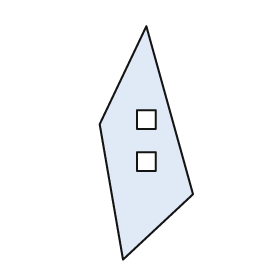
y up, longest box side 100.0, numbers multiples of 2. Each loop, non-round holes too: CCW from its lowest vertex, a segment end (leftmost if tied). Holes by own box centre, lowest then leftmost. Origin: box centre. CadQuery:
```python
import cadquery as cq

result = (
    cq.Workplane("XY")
    .moveTo(-10.0, -50.0)
    .lineTo(20.0, -22.0)
    .lineTo(0.0, 50.0)
    .lineTo(-20.0, 8.0)
    .close()
    .moveTo(-4.0, -12.0)
    .lineTo(4.0, -12.0)
    .lineTo(4.0, -4.0)
    .lineTo(-4.0, -4.0)
    .close()
    .moveTo(-4.0, 6.0)
    .lineTo(4.0, 6.0)
    .lineTo(4.0, 14.0)
    .lineTo(-4.0, 14.0)
    .close()
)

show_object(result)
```